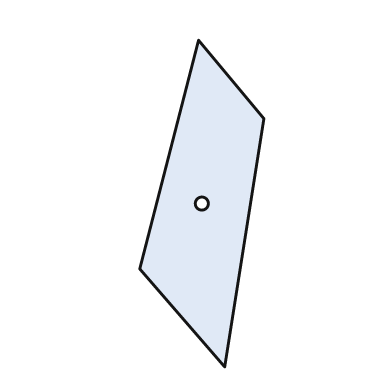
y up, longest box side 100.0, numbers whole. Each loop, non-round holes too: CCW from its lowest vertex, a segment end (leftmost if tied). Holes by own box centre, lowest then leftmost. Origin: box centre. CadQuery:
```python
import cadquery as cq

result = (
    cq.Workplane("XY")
    .moveTo(7.0, -50.0)
    .lineTo(19.0, 26.0)
    .lineTo(-1.0, 50.0)
    .lineTo(-19.0, -20.0)
    .close()
    .moveTo(0.0, 0.0)
    .circle(2.0)
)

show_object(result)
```